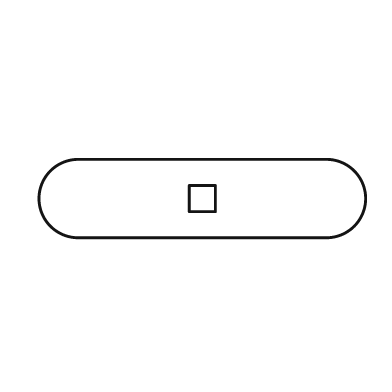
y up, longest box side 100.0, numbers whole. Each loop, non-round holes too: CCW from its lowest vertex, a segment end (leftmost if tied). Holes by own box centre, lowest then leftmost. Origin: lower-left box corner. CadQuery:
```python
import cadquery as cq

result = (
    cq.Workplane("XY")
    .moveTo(12.0, 0.0)
    .lineTo(88.0, 0.0)
    .threePointArc((100.0, 12.0), (88.0, 24.0))
    .lineTo(12.0, 24.0)
    .threePointArc((0.0, 12.0), (12.0, 0.0))
    .close()
    .moveTo(46.0, 8.0)
    .lineTo(54.0, 8.0)
    .lineTo(54.0, 16.0)
    .lineTo(46.0, 16.0)
    .close()
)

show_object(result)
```